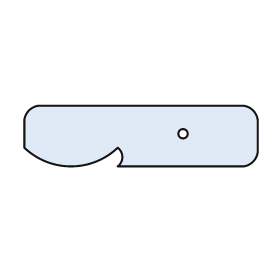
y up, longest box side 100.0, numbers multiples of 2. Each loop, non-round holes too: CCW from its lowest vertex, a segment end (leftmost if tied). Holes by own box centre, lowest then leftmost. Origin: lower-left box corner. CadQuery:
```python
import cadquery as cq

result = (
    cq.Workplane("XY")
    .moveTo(40.0, 0.0)
    .lineTo(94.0, 0.0)
    .threePointArc((98.0, 2.0), (100.0, 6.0))
    .lineTo(100.0, 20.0)
    .threePointArc((98.0, 24.0), (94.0, 26.0))
    .lineTo(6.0, 26.0)
    .threePointArc((2.0, 24.0), (0.0, 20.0))
    .lineTo(0.0, 8.0)
    .threePointArc((20.0, 0.0), (40.0, 8.0))
    .threePointArc((42.0, 4.0), (40.0, 0.0))
    .close()
    .moveTo(68.0, 14.0)
    .circle(2.0)
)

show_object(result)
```